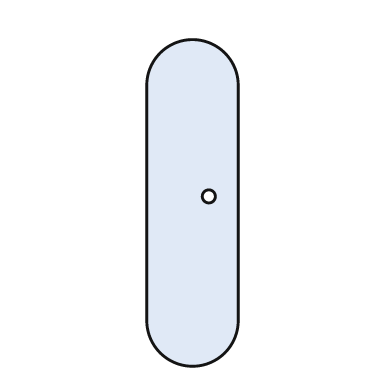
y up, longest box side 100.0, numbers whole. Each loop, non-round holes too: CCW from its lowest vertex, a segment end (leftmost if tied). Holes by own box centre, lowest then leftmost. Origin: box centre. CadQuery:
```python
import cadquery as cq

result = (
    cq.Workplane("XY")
    .moveTo(-14.0, -36.0)
    .threePointArc((0.0, -50.0), (14.0, -36.0))
    .lineTo(14.0, 36.0)
    .threePointArc((0.0, 50.0), (-14.0, 36.0))
    .close()
    .moveTo(5.0, 2.0)
    .circle(2.0)
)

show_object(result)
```